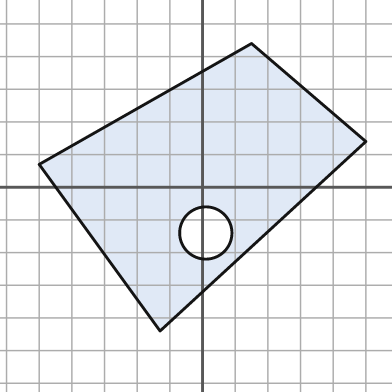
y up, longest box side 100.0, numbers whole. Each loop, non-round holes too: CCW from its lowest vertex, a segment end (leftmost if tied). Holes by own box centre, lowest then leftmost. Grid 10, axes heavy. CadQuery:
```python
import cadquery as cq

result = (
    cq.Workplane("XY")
    .moveTo(-13.0, -44.0)
    .lineTo(50.0, 14.0)
    .lineTo(15.0, 44.0)
    .lineTo(-50.0, 7.0)
    .close()
    .moveTo(1.0, -14.0)
    .circle(8.0)
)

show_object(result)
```